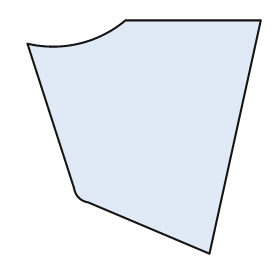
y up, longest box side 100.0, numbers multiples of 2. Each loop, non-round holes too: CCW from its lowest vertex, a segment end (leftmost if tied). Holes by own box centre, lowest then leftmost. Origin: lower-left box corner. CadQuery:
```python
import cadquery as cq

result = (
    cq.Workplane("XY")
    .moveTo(78.0, 0.0)
    .lineTo(100.0, 100.0)
    .lineTo(42.0, 100.0)
    .threePointArc((22.0, 90.0), (0.0, 90.0))
    .lineTo(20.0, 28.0)
    .threePointArc((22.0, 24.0), (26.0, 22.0))
    .close()
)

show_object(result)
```